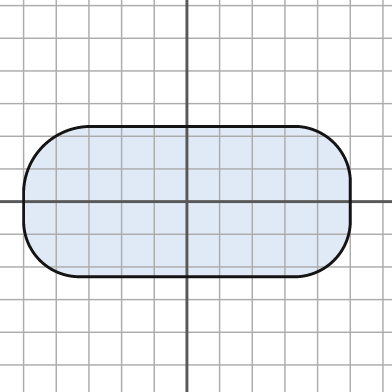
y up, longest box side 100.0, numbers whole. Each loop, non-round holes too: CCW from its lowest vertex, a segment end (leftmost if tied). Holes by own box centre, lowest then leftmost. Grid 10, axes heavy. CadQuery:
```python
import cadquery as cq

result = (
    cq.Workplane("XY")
    .moveTo(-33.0, -23.0)
    .lineTo(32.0, -23.0)
    .threePointArc((45.0, -18.0), (50.0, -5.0))
    .lineTo(50.0, 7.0)
    .threePointArc((45.0, 18.0), (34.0, 23.0))
    .lineTo(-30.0, 23.0)
    .threePointArc((-44.0, 17.0), (-50.0, 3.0))
    .lineTo(-50.0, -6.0)
    .threePointArc((-45.0, -18.0), (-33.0, -23.0))
    .close()
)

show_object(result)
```